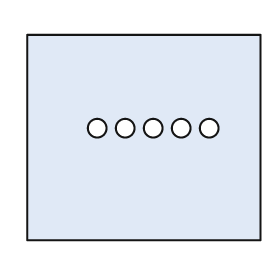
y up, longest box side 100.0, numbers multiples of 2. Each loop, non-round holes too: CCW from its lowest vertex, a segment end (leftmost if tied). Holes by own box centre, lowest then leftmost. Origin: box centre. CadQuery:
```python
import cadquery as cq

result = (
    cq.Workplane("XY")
    .moveTo(-50.0, -44.0)
    .lineTo(50.0, -44.0)
    .lineTo(50.0, 44.0)
    .lineTo(-50.0, 44.0)
    .close()
    .moveTo(-20.0, 4.0)
    .circle(4.0)
    .moveTo(-8.0, 4.0)
    .circle(4.0)
    .moveTo(4.0, 4.0)
    .circle(4.0)
    .moveTo(16.0, 4.0)
    .circle(4.0)
    .moveTo(28.0, 4.0)
    .circle(4.0)
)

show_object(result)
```